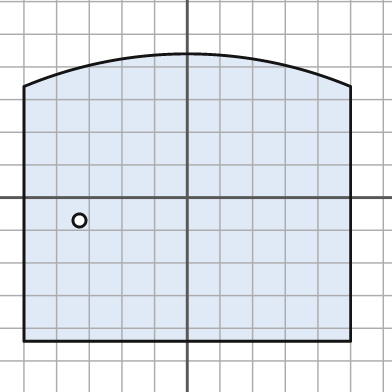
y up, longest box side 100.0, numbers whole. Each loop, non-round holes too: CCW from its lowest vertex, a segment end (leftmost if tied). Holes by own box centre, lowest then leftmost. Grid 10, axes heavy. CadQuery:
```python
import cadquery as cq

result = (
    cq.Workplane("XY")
    .moveTo(-50.0, -44.0)
    .lineTo(50.0, -44.0)
    .lineTo(50.0, 34.0)
    .threePointArc((0.0, 44.0), (-50.0, 34.0))
    .close()
    .moveTo(-33.0, -7.0)
    .circle(2.0)
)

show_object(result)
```